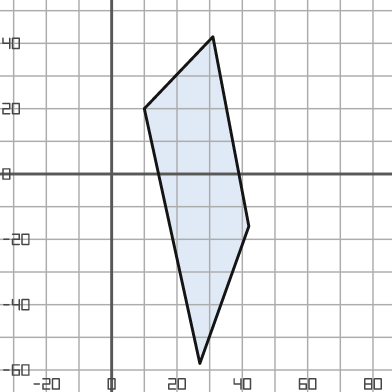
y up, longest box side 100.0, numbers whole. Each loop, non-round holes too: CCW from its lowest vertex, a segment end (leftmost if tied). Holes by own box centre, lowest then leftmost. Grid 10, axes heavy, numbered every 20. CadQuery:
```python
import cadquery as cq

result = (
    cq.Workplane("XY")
    .moveTo(27.0, -58.0)
    .lineTo(42.0, -16.0)
    .lineTo(31.0, 42.0)
    .lineTo(10.0, 20.0)
    .close()
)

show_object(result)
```